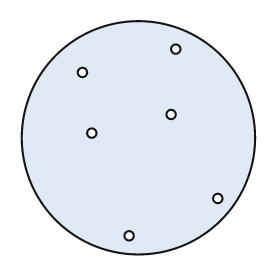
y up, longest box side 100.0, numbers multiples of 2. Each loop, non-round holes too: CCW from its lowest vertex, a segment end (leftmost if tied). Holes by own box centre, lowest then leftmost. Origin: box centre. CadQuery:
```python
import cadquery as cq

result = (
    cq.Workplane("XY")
    .moveTo(0.0, 0.0)
    .circle(50.0)
    .moveTo(-4.0, -42.0)
    .circle(2.0)
    .moveTo(34.0, -26.0)
    .circle(2.0)
    .moveTo(-20.0, 2.0)
    .circle(2.0)
    .moveTo(14.0, 10.0)
    .circle(2.0)
    .moveTo(-24.0, 28.0)
    .circle(2.0)
    .moveTo(16.0, 38.0)
    .circle(2.0)
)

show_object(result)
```